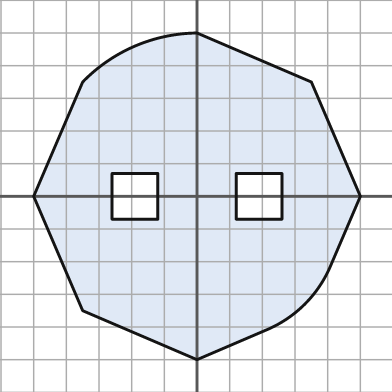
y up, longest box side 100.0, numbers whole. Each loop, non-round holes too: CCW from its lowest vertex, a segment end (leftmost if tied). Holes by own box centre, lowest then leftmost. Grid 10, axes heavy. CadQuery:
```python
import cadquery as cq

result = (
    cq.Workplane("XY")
    .moveTo(0.0, -50.0)
    .lineTo(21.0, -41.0)
    .threePointArc((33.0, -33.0), (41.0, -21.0))
    .lineTo(50.0, 0.0)
    .lineTo(35.0, 35.0)
    .lineTo(0.0, 50.0)
    .threePointArc((-19.0, 46.0), (-35.0, 35.0))
    .lineTo(-50.0, 0.0)
    .lineTo(-35.0, -35.0)
    .close()
    .moveTo(-26.0, -7.0)
    .lineTo(-12.0, -7.0)
    .lineTo(-12.0, 7.0)
    .lineTo(-26.0, 7.0)
    .close()
    .moveTo(12.0, -7.0)
    .lineTo(26.0, -7.0)
    .lineTo(26.0, 7.0)
    .lineTo(12.0, 7.0)
    .close()
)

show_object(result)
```